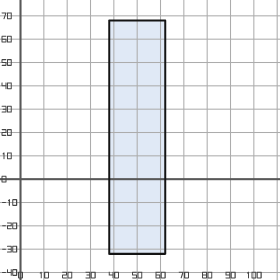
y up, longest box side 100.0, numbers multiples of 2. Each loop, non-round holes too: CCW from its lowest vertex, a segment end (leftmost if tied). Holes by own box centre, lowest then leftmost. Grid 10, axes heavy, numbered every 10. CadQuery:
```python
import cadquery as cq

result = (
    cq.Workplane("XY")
    .moveTo(38.0, -32.0)
    .lineTo(62.0, -32.0)
    .lineTo(62.0, 68.0)
    .lineTo(38.0, 68.0)
    .close()
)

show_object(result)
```